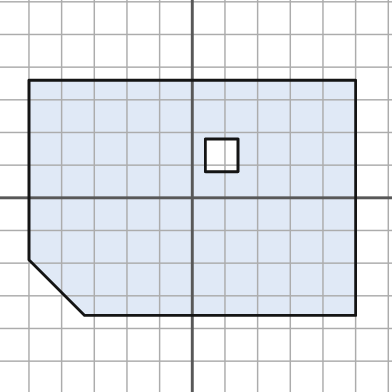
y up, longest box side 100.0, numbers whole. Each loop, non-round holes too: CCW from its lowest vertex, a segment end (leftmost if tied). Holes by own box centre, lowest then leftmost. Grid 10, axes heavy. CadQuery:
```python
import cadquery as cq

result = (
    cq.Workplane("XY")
    .moveTo(-33.0, -36.0)
    .lineTo(50.0, -36.0)
    .lineTo(50.0, 36.0)
    .lineTo(-50.0, 36.0)
    .lineTo(-50.0, -19.0)
    .close()
    .moveTo(4.0, 8.0)
    .lineTo(14.0, 8.0)
    .lineTo(14.0, 18.0)
    .lineTo(4.0, 18.0)
    .close()
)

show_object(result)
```